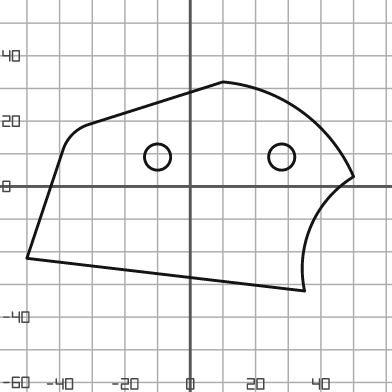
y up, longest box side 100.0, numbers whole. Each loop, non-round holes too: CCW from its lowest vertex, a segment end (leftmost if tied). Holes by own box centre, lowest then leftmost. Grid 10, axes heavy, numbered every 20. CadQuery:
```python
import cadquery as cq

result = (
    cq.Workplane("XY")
    .moveTo(35.0, -32.0)
    .threePointArc((37.0, -12.0), (50.0, 3.0))
    .threePointArc((34.0, 23.0), (10.0, 32.0))
    .lineTo(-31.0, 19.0)
    .threePointArc((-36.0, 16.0), (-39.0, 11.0))
    .lineTo(-50.0, -22.0)
    .close()
    .moveTo(-10.0, 9.0)
    .circle(4.0)
    .moveTo(28.0, 9.0)
    .circle(4.0)
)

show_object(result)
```